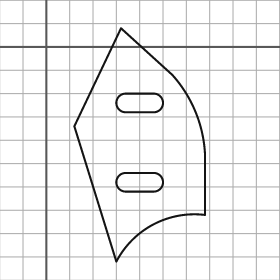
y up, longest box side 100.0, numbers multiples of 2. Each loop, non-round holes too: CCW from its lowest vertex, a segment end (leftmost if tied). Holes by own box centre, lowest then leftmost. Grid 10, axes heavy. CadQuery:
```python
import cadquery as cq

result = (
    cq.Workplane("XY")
    .moveTo(30.0, -92.0)
    .threePointArc((46.0, -76.0), (68.0, -72.0))
    .lineTo(68.0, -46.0)
    .threePointArc((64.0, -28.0), (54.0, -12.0))
    .lineTo(32.0, 8.0)
    .lineTo(12.0, -34.0)
    .close()
    .moveTo(34.0, -62.0)
    .lineTo(46.0, -62.0)
    .threePointArc((50.0, -58.0), (46.0, -54.0))
    .lineTo(34.0, -54.0)
    .threePointArc((30.0, -58.0), (34.0, -62.0))
    .close()
    .moveTo(34.0, -28.0)
    .lineTo(46.0, -28.0)
    .threePointArc((50.0, -24.0), (46.0, -20.0))
    .lineTo(34.0, -20.0)
    .threePointArc((30.0, -24.0), (34.0, -28.0))
    .close()
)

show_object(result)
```